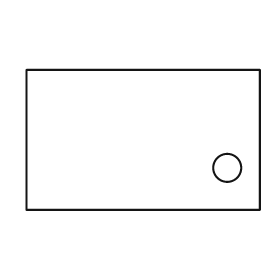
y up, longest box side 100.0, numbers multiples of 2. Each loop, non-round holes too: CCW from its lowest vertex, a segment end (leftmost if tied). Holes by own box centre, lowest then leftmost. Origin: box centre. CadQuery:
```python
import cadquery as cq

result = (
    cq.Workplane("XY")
    .moveTo(-50.0, -30.0)
    .lineTo(50.0, -30.0)
    .lineTo(50.0, 30.0)
    .lineTo(-50.0, 30.0)
    .close()
    .moveTo(36.0, -12.0)
    .circle(6.0)
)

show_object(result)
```